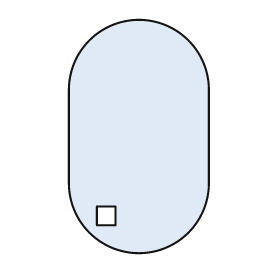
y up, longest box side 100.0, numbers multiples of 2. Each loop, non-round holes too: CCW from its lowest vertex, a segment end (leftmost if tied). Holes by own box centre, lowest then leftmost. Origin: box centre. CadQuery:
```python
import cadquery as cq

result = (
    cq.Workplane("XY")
    .moveTo(-30.0, -20.0)
    .threePointArc((0.0, -50.0), (30.0, -20.0))
    .lineTo(30.0, 20.0)
    .threePointArc((0.0, 50.0), (-30.0, 20.0))
    .close()
    .moveTo(-18.0, -38.0)
    .lineTo(-10.0, -38.0)
    .lineTo(-10.0, -30.0)
    .lineTo(-18.0, -30.0)
    .close()
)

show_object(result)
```